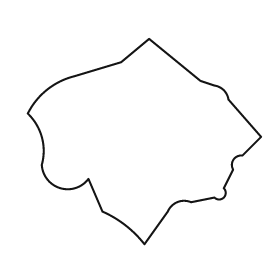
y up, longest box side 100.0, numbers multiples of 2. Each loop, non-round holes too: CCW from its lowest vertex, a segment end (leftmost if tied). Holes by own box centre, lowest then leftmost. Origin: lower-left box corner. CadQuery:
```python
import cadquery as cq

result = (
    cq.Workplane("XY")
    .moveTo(50.0, 0.0)
    .lineTo(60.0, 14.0)
    .threePointArc((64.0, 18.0), (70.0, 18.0))
    .lineTo(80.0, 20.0)
    .threePointArc((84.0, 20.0), (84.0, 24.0))
    .lineTo(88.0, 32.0)
    .threePointArc((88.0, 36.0), (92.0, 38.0))
    .lineTo(100.0, 46.0)
    .lineTo(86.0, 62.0)
    .threePointArc((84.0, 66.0), (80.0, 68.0))
    .lineTo(74.0, 70.0)
    .lineTo(52.0, 88.0)
    .lineTo(40.0, 78.0)
    .lineTo(20.0, 72.0)
    .threePointArc((8.0, 66.0), (0.0, 56.0))
    .threePointArc((6.0, 46.0), (6.0, 34.0))
    .threePointArc((14.0, 24.0), (26.0, 28.0))
    .lineTo(32.0, 14.0)
    .threePointArc((42.0, 8.0), (50.0, 0.0))
    .close()
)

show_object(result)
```